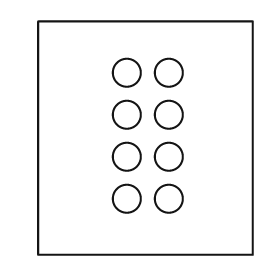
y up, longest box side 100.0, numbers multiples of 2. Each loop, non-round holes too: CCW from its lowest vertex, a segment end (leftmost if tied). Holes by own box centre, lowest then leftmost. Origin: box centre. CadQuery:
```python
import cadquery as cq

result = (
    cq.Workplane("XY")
    .moveTo(-46.0, -50.0)
    .lineTo(46.0, -50.0)
    .lineTo(46.0, 50.0)
    .lineTo(-46.0, 50.0)
    .close()
    .moveTo(-8.0, -26.0)
    .circle(6.0)
    .moveTo(10.0, -26.0)
    .circle(6.0)
    .moveTo(-8.0, -8.0)
    .circle(6.0)
    .moveTo(10.0, -8.0)
    .circle(6.0)
    .moveTo(-8.0, 10.0)
    .circle(6.0)
    .moveTo(10.0, 10.0)
    .circle(6.0)
    .moveTo(-8.0, 28.0)
    .circle(6.0)
    .moveTo(10.0, 28.0)
    .circle(6.0)
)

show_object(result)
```